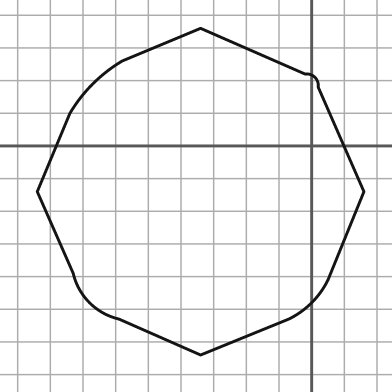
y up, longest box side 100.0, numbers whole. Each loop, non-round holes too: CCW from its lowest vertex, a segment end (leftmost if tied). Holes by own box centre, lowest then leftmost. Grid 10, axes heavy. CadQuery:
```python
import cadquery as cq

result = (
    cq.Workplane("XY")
    .moveTo(-34.0, -64.0)
    .lineTo(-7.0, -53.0)
    .threePointArc((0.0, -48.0), (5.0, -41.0))
    .lineTo(16.0, -14.0)
    .lineTo(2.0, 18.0)
    .threePointArc((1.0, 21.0), (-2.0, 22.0))
    .lineTo(-34.0, 36.0)
    .lineTo(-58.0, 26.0)
    .threePointArc((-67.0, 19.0), (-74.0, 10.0))
    .lineTo(-84.0, -14.0)
    .lineTo(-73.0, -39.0)
    .threePointArc((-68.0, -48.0), (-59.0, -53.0))
    .close()
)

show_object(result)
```